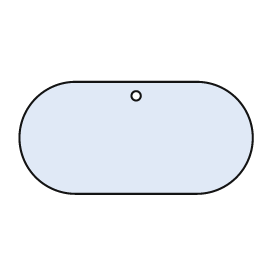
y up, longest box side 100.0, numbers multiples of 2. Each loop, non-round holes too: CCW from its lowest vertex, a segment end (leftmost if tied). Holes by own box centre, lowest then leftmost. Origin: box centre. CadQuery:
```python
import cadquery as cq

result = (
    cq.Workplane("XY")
    .moveTo(-26.0, -24.0)
    .lineTo(26.0, -24.0)
    .threePointArc((50.0, 0.0), (26.0, 24.0))
    .lineTo(-26.0, 24.0)
    .threePointArc((-50.0, 0.0), (-26.0, -24.0))
    .close()
    .moveTo(0.0, 18.0)
    .circle(2.0)
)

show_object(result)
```